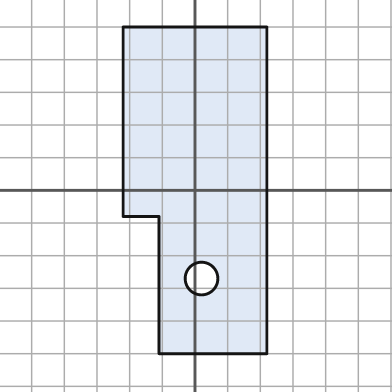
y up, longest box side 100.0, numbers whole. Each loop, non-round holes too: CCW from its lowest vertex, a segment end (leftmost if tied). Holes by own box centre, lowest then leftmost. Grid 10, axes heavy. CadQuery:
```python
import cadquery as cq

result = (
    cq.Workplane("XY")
    .moveTo(-11.0, -50.0)
    .lineTo(22.0, -50.0)
    .lineTo(22.0, 50.0)
    .lineTo(-22.0, 50.0)
    .lineTo(-22.0, -8.0)
    .lineTo(-11.0, -8.0)
    .close()
    .moveTo(2.0, -27.0)
    .circle(5.0)
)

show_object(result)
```